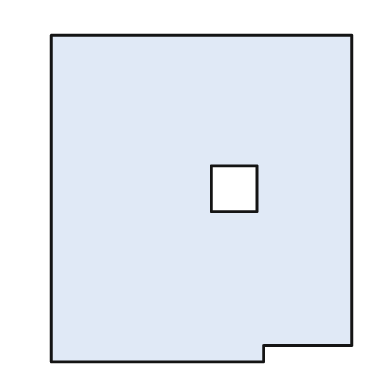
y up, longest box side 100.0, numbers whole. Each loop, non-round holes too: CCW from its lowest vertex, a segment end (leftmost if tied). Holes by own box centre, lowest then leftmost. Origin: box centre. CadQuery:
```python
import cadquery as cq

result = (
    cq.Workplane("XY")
    .moveTo(-46.0, -50.0)
    .lineTo(19.0, -50.0)
    .lineTo(19.0, -45.0)
    .lineTo(46.0, -45.0)
    .lineTo(46.0, 50.0)
    .lineTo(-46.0, 50.0)
    .close()
    .moveTo(3.0, -4.0)
    .lineTo(17.0, -4.0)
    .lineTo(17.0, 10.0)
    .lineTo(3.0, 10.0)
    .close()
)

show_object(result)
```